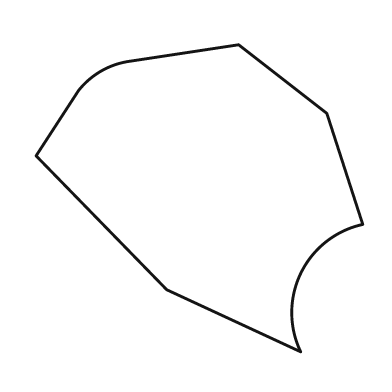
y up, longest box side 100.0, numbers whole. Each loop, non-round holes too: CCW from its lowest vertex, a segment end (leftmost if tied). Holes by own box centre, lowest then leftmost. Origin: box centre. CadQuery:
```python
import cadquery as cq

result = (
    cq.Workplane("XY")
    .moveTo(31.0, -47.0)
    .threePointArc((31.0, -23.0), (50.0, -8.0))
    .lineTo(39.0, 26.0)
    .lineTo(12.0, 47.0)
    .lineTo(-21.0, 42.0)
    .threePointArc((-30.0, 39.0), (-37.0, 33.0))
    .lineTo(-50.0, 13.0)
    .lineTo(-10.0, -28.0)
    .close()
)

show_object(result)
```